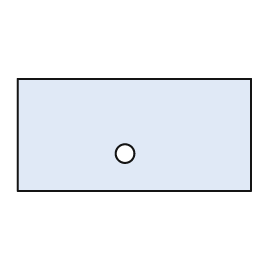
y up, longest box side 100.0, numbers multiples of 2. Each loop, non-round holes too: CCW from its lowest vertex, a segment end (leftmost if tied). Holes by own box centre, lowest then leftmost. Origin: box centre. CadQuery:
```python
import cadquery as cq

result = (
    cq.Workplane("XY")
    .moveTo(-50.0, -24.0)
    .lineTo(50.0, -24.0)
    .lineTo(50.0, 24.0)
    .lineTo(-50.0, 24.0)
    .close()
    .moveTo(-4.0, -8.0)
    .circle(4.0)
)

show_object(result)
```